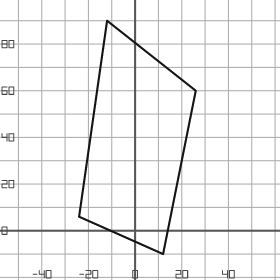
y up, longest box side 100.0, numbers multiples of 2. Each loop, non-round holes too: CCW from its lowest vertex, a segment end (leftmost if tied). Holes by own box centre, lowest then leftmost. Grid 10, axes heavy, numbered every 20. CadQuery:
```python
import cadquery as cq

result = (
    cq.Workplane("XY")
    .moveTo(12.0, -10.0)
    .lineTo(26.0, 60.0)
    .lineTo(-12.0, 90.0)
    .lineTo(-24.0, 6.0)
    .close()
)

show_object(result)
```